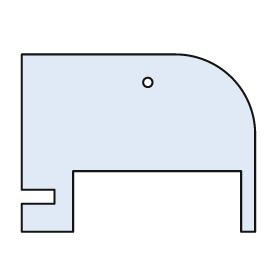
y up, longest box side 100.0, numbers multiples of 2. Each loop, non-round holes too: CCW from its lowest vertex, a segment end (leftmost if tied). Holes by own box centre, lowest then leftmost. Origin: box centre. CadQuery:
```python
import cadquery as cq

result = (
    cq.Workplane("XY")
    .moveTo(-50.0, -38.0)
    .lineTo(-28.0, -38.0)
    .lineTo(-28.0, -12.0)
    .lineTo(44.0, -12.0)
    .lineTo(44.0, -38.0)
    .lineTo(50.0, -38.0)
    .lineTo(50.0, 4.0)
    .threePointArc((40.0, 28.0), (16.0, 38.0))
    .lineTo(-50.0, 38.0)
    .lineTo(-50.0, -20.0)
    .lineTo(-36.0, -20.0)
    .lineTo(-36.0, -26.0)
    .lineTo(-50.0, -26.0)
    .close()
    .moveTo(4.0, 26.0)
    .circle(2.0)
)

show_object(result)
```